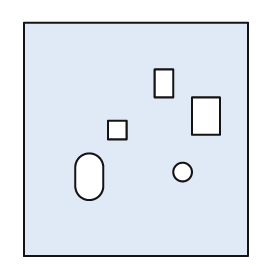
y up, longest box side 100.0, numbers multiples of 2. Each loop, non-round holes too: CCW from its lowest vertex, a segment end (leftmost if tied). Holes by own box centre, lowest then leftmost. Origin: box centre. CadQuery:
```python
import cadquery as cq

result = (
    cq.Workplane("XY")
    .moveTo(-48.0, -50.0)
    .lineTo(48.0, -50.0)
    .lineTo(48.0, 50.0)
    .lineTo(-48.0, 50.0)
    .close()
    .moveTo(-26.0, -20.0)
    .threePointArc((-20.0, -26.0), (-14.0, -20.0))
    .lineTo(-14.0, -12.0)
    .threePointArc((-20.0, -6.0), (-26.0, -12.0))
    .close()
    .moveTo(20.0, -14.0)
    .circle(4.0)
    .moveTo(-12.0, 0.0)
    .lineTo(-4.0, 0.0)
    .lineTo(-4.0, 8.0)
    .lineTo(-12.0, 8.0)
    .close()
    .moveTo(24.0, 2.0)
    .lineTo(36.0, 2.0)
    .lineTo(36.0, 18.0)
    .lineTo(24.0, 18.0)
    .close()
    .moveTo(8.0, 18.0)
    .lineTo(16.0, 18.0)
    .lineTo(16.0, 30.0)
    .lineTo(8.0, 30.0)
    .close()
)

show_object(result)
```